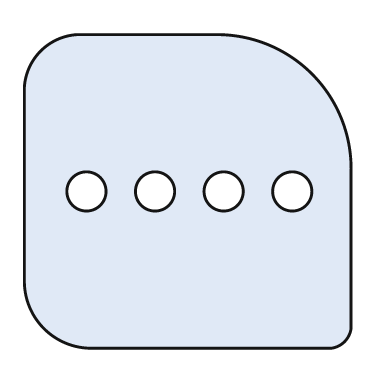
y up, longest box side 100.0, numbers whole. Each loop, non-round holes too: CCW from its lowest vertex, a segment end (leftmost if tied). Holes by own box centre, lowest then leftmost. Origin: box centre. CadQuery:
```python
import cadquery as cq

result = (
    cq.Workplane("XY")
    .moveTo(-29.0, -48.0)
    .lineTo(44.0, -48.0)
    .threePointArc((48.0, -46.0), (50.0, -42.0))
    .lineTo(50.0, 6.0)
    .threePointArc((38.0, 36.0), (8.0, 48.0))
    .lineTo(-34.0, 48.0)
    .threePointArc((-45.0, 43.0), (-50.0, 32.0))
    .lineTo(-50.0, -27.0)
    .threePointArc((-44.0, -42.0), (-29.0, -48.0))
    .close()
    .moveTo(-31.0, 0.0)
    .circle(6.0)
    .moveTo(-10.0, 0.0)
    .circle(6.0)
    .moveTo(11.0, 0.0)
    .circle(6.0)
    .moveTo(32.0, 0.0)
    .circle(6.0)
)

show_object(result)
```